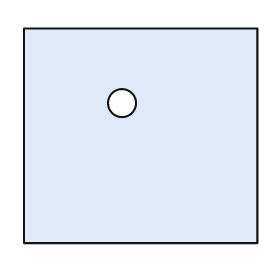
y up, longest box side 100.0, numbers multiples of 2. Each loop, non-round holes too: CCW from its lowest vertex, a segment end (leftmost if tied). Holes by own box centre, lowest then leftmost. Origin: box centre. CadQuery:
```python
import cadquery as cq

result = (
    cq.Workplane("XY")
    .moveTo(-50.0, -46.0)
    .lineTo(50.0, -46.0)
    .lineTo(50.0, 46.0)
    .lineTo(-50.0, 46.0)
    .close()
    .moveTo(-8.0, 14.0)
    .circle(6.0)
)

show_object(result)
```